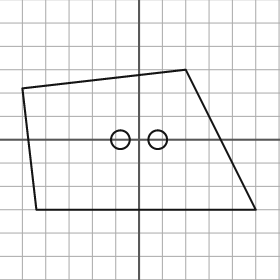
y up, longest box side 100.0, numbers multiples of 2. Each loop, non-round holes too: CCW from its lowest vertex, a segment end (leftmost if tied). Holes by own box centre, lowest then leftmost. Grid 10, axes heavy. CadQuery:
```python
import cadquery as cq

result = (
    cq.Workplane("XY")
    .moveTo(-44.0, -30.0)
    .lineTo(50.0, -30.0)
    .lineTo(20.0, 30.0)
    .lineTo(-50.0, 22.0)
    .close()
    .moveTo(-8.0, 0.0)
    .circle(4.0)
    .moveTo(8.0, 0.0)
    .circle(4.0)
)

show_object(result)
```